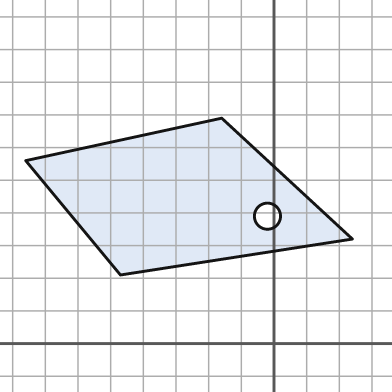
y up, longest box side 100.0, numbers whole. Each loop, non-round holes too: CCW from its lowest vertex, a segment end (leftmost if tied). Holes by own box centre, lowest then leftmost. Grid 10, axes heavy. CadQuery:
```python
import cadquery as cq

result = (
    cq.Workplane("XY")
    .moveTo(-47.0, 21.0)
    .lineTo(24.0, 32.0)
    .lineTo(-16.0, 69.0)
    .lineTo(-76.0, 56.0)
    .close()
    .moveTo(-2.0, 39.0)
    .circle(4.0)
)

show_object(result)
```